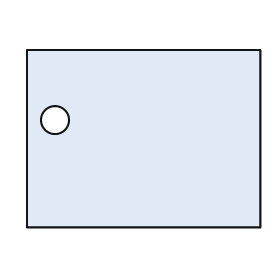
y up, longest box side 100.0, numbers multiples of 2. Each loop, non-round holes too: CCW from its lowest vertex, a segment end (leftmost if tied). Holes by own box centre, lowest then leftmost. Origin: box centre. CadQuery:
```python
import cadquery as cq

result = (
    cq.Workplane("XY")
    .moveTo(-50.0, -38.0)
    .lineTo(50.0, -38.0)
    .lineTo(50.0, 38.0)
    .lineTo(-50.0, 38.0)
    .close()
    .moveTo(-38.0, 8.0)
    .circle(6.0)
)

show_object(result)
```